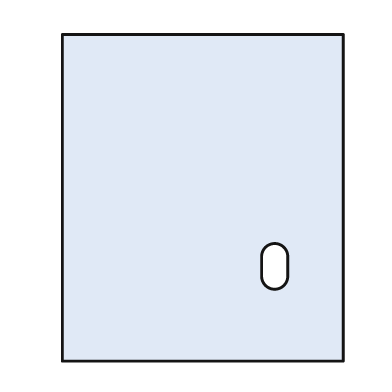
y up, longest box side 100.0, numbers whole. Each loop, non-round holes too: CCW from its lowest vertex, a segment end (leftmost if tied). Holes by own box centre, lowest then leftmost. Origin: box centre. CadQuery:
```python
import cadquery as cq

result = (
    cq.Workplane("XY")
    .moveTo(-43.0, -50.0)
    .lineTo(43.0, -50.0)
    .lineTo(43.0, 50.0)
    .lineTo(-43.0, 50.0)
    .close()
    .moveTo(18.0, -24.0)
    .threePointArc((22.0, -28.0), (26.0, -24.0))
    .lineTo(26.0, -18.0)
    .threePointArc((22.0, -14.0), (18.0, -18.0))
    .close()
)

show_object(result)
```